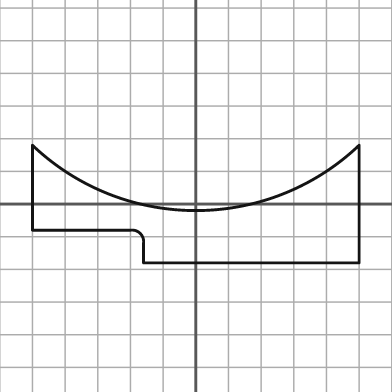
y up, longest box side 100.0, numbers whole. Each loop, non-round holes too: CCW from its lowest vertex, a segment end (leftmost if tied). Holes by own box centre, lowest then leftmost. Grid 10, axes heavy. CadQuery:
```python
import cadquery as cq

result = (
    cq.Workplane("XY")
    .moveTo(-16.0, -18.0)
    .lineTo(50.0, -18.0)
    .lineTo(50.0, 18.0)
    .threePointArc((0.0, -2.0), (-50.0, 18.0))
    .lineTo(-50.0, -8.0)
    .lineTo(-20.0, -8.0)
    .threePointArc((-17.0, -9.0), (-16.0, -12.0))
    .close()
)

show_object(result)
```